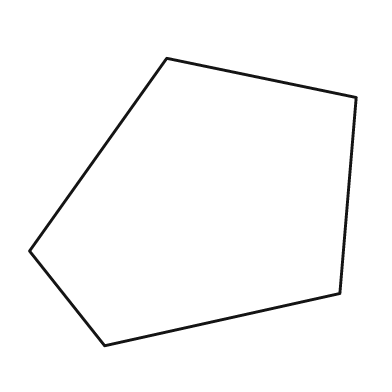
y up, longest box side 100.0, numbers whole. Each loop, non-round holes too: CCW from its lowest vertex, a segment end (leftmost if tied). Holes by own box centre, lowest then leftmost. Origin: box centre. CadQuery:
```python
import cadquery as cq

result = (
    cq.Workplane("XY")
    .moveTo(-27.0, -44.0)
    .lineTo(45.0, -28.0)
    .lineTo(50.0, 32.0)
    .lineTo(-8.0, 44.0)
    .lineTo(-50.0, -15.0)
    .close()
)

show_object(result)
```